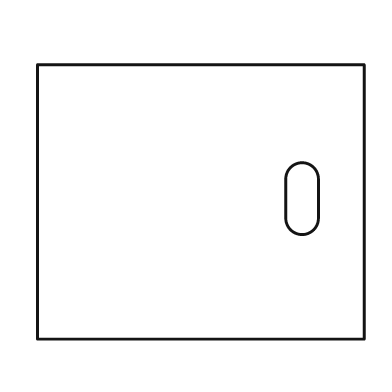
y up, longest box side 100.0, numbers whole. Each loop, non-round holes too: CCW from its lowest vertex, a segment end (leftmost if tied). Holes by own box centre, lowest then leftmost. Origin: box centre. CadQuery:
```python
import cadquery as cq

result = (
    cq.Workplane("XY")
    .moveTo(-50.0, -42.0)
    .lineTo(50.0, -42.0)
    .lineTo(50.0, 42.0)
    .lineTo(-50.0, 42.0)
    .close()
    .moveTo(26.0, -5.0)
    .threePointArc((31.0, -10.0), (36.0, -5.0))
    .lineTo(36.0, 7.0)
    .threePointArc((31.0, 12.0), (26.0, 7.0))
    .close()
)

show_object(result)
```